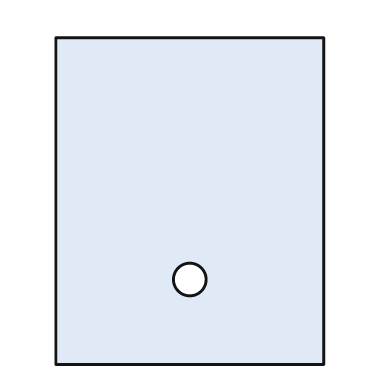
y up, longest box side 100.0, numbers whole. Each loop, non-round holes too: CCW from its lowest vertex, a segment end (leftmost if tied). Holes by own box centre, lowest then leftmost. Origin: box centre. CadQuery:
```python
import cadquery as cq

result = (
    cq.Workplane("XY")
    .moveTo(-41.0, -50.0)
    .lineTo(41.0, -50.0)
    .lineTo(41.0, 50.0)
    .lineTo(-41.0, 50.0)
    .close()
    .moveTo(0.0, -24.0)
    .circle(5.0)
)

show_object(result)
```